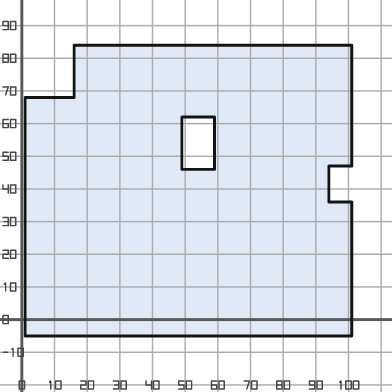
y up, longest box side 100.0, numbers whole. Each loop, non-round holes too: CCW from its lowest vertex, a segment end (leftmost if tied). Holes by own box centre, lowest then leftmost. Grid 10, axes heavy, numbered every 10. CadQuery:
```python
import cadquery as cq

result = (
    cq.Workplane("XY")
    .moveTo(1.0, -5.0)
    .lineTo(101.0, -5.0)
    .lineTo(101.0, 36.0)
    .lineTo(94.0, 36.0)
    .lineTo(94.0, 47.0)
    .lineTo(101.0, 47.0)
    .lineTo(101.0, 84.0)
    .lineTo(16.0, 84.0)
    .lineTo(16.0, 68.0)
    .lineTo(1.0, 68.0)
    .close()
    .moveTo(49.0, 46.0)
    .lineTo(59.0, 46.0)
    .lineTo(59.0, 62.0)
    .lineTo(49.0, 62.0)
    .close()
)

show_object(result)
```